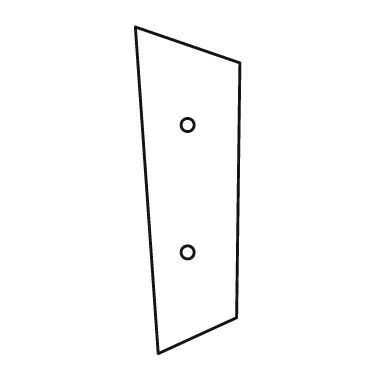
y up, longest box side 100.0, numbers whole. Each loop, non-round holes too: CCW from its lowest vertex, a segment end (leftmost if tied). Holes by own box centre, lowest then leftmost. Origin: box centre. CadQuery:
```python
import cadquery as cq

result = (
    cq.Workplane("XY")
    .moveTo(-9.0, -50.0)
    .lineTo(15.0, -39.0)
    .lineTo(16.0, 39.0)
    .lineTo(-16.0, 50.0)
    .close()
    .moveTo(0.0, -19.0)
    .circle(2.0)
    .moveTo(0.0, 20.0)
    .circle(2.0)
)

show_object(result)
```